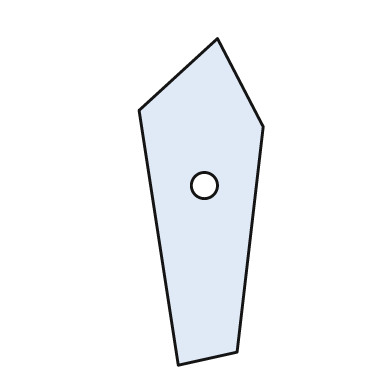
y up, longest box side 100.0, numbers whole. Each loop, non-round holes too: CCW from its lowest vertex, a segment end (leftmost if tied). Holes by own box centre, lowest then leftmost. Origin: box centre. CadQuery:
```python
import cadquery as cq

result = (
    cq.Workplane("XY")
    .moveTo(-7.0, -50.0)
    .lineTo(11.0, -46.0)
    .lineTo(19.0, 23.0)
    .lineTo(5.0, 50.0)
    .lineTo(-19.0, 28.0)
    .close()
    .moveTo(1.0, 5.0)
    .circle(4.0)
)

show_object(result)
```